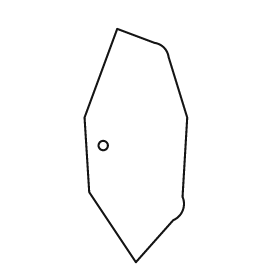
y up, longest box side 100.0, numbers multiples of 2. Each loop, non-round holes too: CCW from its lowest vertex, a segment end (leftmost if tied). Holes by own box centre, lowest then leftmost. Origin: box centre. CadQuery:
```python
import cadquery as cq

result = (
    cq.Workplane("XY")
    .moveTo(0.0, -50.0)
    .lineTo(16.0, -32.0)
    .threePointArc((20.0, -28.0), (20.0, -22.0))
    .lineTo(22.0, 12.0)
    .lineTo(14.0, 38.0)
    .threePointArc((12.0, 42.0), (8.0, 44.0))
    .lineTo(-8.0, 50.0)
    .lineTo(-22.0, 12.0)
    .lineTo(-20.0, -20.0)
    .close()
    .moveTo(-14.0, 0.0)
    .circle(2.0)
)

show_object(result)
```